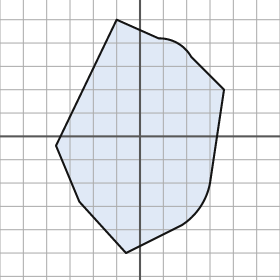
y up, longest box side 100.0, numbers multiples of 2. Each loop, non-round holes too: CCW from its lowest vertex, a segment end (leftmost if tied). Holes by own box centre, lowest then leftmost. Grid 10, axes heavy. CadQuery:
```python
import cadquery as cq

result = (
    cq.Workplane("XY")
    .moveTo(-6.0, -50.0)
    .lineTo(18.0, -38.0)
    .threePointArc((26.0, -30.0), (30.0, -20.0))
    .lineTo(36.0, 20.0)
    .lineTo(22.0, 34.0)
    .threePointArc((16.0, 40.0), (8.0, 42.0))
    .lineTo(-10.0, 50.0)
    .lineTo(-36.0, -4.0)
    .lineTo(-26.0, -28.0)
    .close()
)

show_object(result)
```